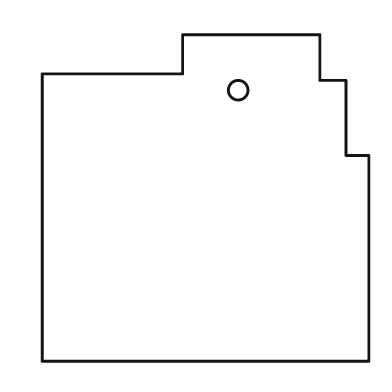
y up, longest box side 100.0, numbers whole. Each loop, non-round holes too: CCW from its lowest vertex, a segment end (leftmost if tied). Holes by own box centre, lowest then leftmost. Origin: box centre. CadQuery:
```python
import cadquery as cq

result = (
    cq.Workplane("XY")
    .moveTo(-50.0, -50.0)
    .lineTo(50.0, -50.0)
    .lineTo(50.0, 13.0)
    .lineTo(43.0, 13.0)
    .lineTo(43.0, 36.0)
    .lineTo(35.0, 36.0)
    .lineTo(35.0, 50.0)
    .lineTo(-7.0, 50.0)
    .lineTo(-7.0, 38.0)
    .lineTo(-50.0, 38.0)
    .close()
    .moveTo(10.0, 33.0)
    .circle(3.0)
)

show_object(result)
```